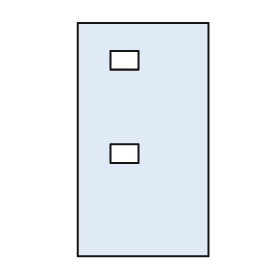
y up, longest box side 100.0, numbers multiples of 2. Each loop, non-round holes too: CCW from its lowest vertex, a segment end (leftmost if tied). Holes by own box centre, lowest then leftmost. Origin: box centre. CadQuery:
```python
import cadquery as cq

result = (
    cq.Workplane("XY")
    .moveTo(-28.0, -50.0)
    .lineTo(28.0, -50.0)
    .lineTo(28.0, 50.0)
    .lineTo(-28.0, 50.0)
    .close()
    .moveTo(-14.0, -10.0)
    .lineTo(-2.0, -10.0)
    .lineTo(-2.0, -2.0)
    .lineTo(-14.0, -2.0)
    .close()
    .moveTo(-14.0, 30.0)
    .lineTo(-2.0, 30.0)
    .lineTo(-2.0, 38.0)
    .lineTo(-14.0, 38.0)
    .close()
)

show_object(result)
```